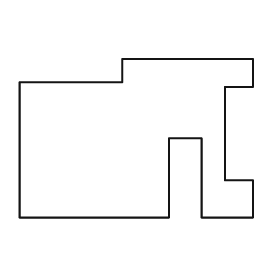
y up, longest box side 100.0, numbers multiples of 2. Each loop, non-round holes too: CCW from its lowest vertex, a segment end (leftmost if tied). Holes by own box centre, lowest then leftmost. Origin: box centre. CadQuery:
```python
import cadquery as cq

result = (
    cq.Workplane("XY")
    .moveTo(-50.0, -34.0)
    .lineTo(14.0, -34.0)
    .lineTo(14.0, 0.0)
    .lineTo(28.0, 0.0)
    .lineTo(28.0, -34.0)
    .lineTo(50.0, -34.0)
    .lineTo(50.0, -18.0)
    .lineTo(38.0, -18.0)
    .lineTo(38.0, 22.0)
    .lineTo(50.0, 22.0)
    .lineTo(50.0, 34.0)
    .lineTo(-6.0, 34.0)
    .lineTo(-6.0, 24.0)
    .lineTo(-50.0, 24.0)
    .close()
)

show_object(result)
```